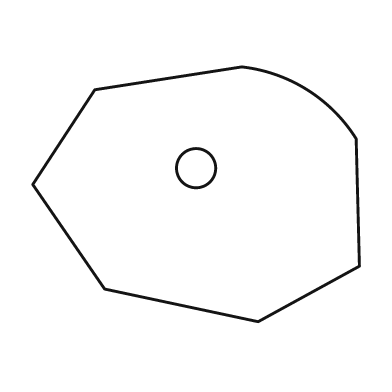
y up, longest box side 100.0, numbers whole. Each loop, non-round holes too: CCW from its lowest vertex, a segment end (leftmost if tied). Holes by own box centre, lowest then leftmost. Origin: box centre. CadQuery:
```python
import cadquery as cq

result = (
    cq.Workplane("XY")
    .moveTo(19.0, -39.0)
    .lineTo(50.0, -22.0)
    .lineTo(49.0, 17.0)
    .threePointArc((34.0, 32.0), (14.0, 39.0))
    .lineTo(-31.0, 32.0)
    .lineTo(-50.0, 3.0)
    .lineTo(-28.0, -29.0)
    .close()
    .moveTo(0.0, 8.0)
    .circle(6.0)
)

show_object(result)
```